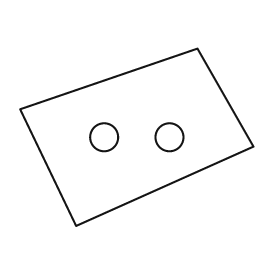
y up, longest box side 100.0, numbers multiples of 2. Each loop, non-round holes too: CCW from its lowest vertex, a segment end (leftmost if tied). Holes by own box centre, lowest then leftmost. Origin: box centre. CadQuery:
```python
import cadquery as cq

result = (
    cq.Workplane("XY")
    .moveTo(-26.0, -38.0)
    .lineTo(50.0, -4.0)
    .lineTo(26.0, 38.0)
    .lineTo(-50.0, 12.0)
    .close()
    .moveTo(-14.0, 0.0)
    .circle(6.0)
    .moveTo(14.0, 0.0)
    .circle(6.0)
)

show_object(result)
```